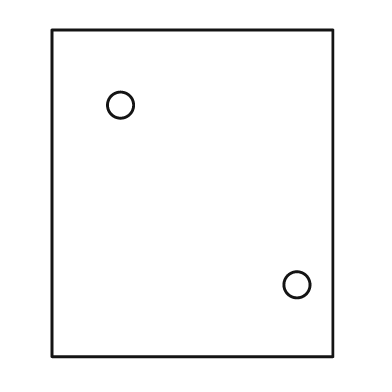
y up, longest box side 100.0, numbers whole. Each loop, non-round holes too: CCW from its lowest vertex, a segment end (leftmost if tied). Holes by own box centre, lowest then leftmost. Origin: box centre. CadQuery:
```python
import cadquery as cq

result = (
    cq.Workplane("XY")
    .moveTo(-43.0, -50.0)
    .lineTo(43.0, -50.0)
    .lineTo(43.0, 50.0)
    .lineTo(-43.0, 50.0)
    .close()
    .moveTo(32.0, -28.0)
    .circle(4.0)
    .moveTo(-22.0, 27.0)
    .circle(4.0)
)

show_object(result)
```